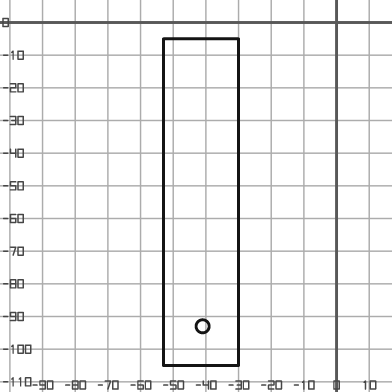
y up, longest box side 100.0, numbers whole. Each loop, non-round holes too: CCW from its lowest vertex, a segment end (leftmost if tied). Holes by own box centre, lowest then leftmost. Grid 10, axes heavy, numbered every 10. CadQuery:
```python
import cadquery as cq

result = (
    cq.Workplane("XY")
    .moveTo(-53.0, -105.0)
    .lineTo(-30.0, -105.0)
    .lineTo(-30.0, -5.0)
    .lineTo(-53.0, -5.0)
    .close()
    .moveTo(-41.0, -93.0)
    .circle(2.0)
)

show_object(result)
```